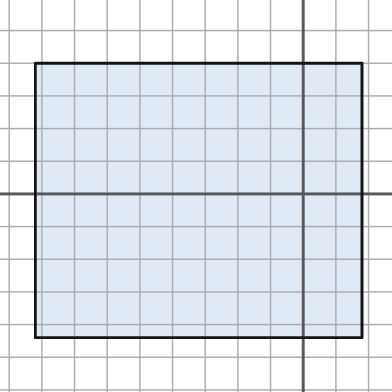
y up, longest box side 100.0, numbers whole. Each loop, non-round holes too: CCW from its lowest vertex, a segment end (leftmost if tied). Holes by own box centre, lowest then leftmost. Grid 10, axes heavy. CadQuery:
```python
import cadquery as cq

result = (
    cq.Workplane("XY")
    .moveTo(-82.0, -44.0)
    .lineTo(18.0, -44.0)
    .lineTo(18.0, 40.0)
    .lineTo(-82.0, 40.0)
    .close()
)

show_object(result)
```